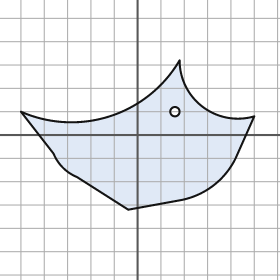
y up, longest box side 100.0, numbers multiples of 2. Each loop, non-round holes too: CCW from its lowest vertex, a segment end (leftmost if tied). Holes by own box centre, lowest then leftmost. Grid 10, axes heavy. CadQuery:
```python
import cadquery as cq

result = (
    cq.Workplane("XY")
    .moveTo(-4.0, -32.0)
    .lineTo(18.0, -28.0)
    .threePointArc((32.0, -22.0), (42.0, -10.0))
    .lineTo(50.0, 8.0)
    .threePointArc((28.0, 12.0), (18.0, 32.0))
    .threePointArc((-12.0, 8.0), (-50.0, 10.0))
    .lineTo(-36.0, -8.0)
    .threePointArc((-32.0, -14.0), (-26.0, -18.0))
    .close()
    .moveTo(16.0, 10.0)
    .circle(2.0)
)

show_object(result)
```